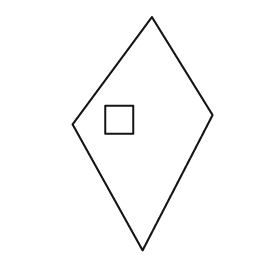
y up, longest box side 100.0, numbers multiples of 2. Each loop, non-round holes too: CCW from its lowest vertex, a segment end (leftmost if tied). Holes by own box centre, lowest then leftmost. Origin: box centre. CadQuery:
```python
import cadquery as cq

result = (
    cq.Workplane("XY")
    .moveTo(0.0, -50.0)
    .lineTo(30.0, 8.0)
    .lineTo(4.0, 50.0)
    .lineTo(-30.0, 4.0)
    .close()
    .moveTo(-16.0, 0.0)
    .lineTo(-4.0, 0.0)
    .lineTo(-4.0, 12.0)
    .lineTo(-16.0, 12.0)
    .close()
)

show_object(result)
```